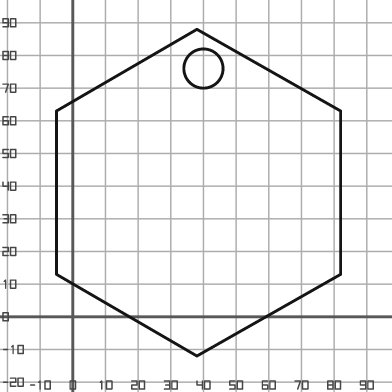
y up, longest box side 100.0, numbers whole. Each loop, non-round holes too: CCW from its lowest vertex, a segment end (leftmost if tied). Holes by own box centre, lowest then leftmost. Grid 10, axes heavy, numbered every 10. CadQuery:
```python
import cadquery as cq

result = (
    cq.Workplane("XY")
    .moveTo(38.0, -12.0)
    .lineTo(82.0, 13.0)
    .lineTo(82.0, 63.0)
    .lineTo(38.0, 88.0)
    .lineTo(-5.0, 63.0)
    .lineTo(-5.0, 13.0)
    .close()
    .moveTo(40.0, 76.0)
    .circle(6.0)
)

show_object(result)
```